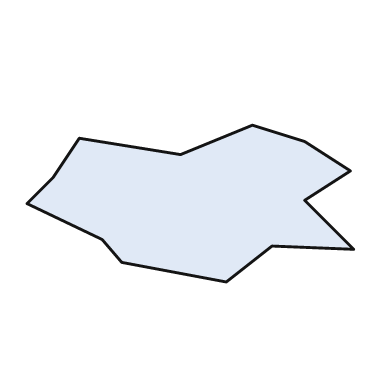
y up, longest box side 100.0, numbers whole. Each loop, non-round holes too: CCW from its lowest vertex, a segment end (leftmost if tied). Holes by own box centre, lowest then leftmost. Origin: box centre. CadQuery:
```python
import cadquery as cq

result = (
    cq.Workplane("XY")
    .moveTo(11.0, -24.0)
    .lineTo(25.0, -13.0)
    .lineTo(50.0, -14.0)
    .lineTo(35.0, 1.0)
    .lineTo(49.0, 10.0)
    .lineTo(35.0, 19.0)
    .lineTo(19.0, 24.0)
    .lineTo(-3.0, 15.0)
    .lineTo(-34.0, 20.0)
    .lineTo(-42.0, 8.0)
    .lineTo(-50.0, 0.0)
    .lineTo(-27.0, -11.0)
    .lineTo(-21.0, -18.0)
    .close()
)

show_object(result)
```